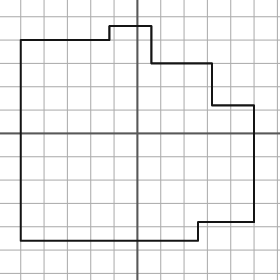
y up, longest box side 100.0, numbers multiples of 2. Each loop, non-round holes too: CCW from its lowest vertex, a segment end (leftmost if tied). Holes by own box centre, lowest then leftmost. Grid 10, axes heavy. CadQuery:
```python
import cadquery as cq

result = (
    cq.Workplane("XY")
    .moveTo(-50.0, -46.0)
    .lineTo(26.0, -46.0)
    .lineTo(26.0, -38.0)
    .lineTo(50.0, -38.0)
    .lineTo(50.0, 12.0)
    .lineTo(32.0, 12.0)
    .lineTo(32.0, 30.0)
    .lineTo(6.0, 30.0)
    .lineTo(6.0, 46.0)
    .lineTo(-12.0, 46.0)
    .lineTo(-12.0, 40.0)
    .lineTo(-50.0, 40.0)
    .close()
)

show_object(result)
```